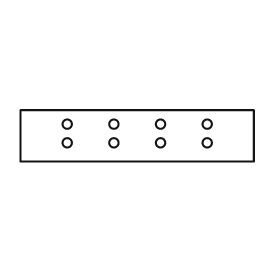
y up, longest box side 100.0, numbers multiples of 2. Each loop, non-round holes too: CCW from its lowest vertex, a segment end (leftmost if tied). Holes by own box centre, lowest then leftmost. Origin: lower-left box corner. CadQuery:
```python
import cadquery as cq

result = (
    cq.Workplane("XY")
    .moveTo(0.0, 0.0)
    .lineTo(100.0, 0.0)
    .lineTo(100.0, 22.0)
    .lineTo(0.0, 22.0)
    .close()
    .moveTo(20.0, 8.0)
    .circle(2.0)
    .moveTo(40.0, 8.0)
    .circle(2.0)
    .moveTo(60.0, 8.0)
    .circle(2.0)
    .moveTo(80.0, 8.0)
    .circle(2.0)
    .moveTo(20.0, 16.0)
    .circle(2.0)
    .moveTo(40.0, 16.0)
    .circle(2.0)
    .moveTo(60.0, 16.0)
    .circle(2.0)
    .moveTo(80.0, 16.0)
    .circle(2.0)
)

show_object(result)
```